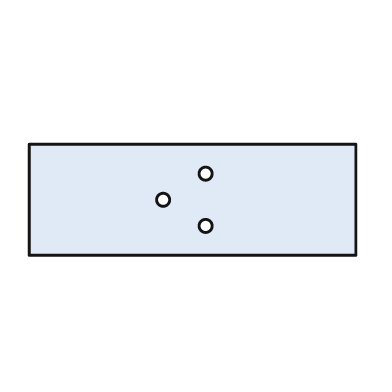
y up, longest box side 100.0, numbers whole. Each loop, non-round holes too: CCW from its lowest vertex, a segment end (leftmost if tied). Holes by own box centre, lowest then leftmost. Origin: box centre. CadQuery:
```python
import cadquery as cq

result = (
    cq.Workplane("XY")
    .moveTo(-50.0, -17.0)
    .lineTo(50.0, -17.0)
    .lineTo(50.0, 17.0)
    .lineTo(-50.0, 17.0)
    .close()
    .moveTo(4.0, -8.0)
    .circle(2.0)
    .moveTo(-9.0, 0.0)
    .circle(2.0)
    .moveTo(4.0, 8.0)
    .circle(2.0)
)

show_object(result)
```